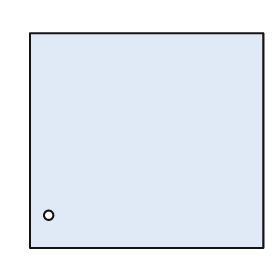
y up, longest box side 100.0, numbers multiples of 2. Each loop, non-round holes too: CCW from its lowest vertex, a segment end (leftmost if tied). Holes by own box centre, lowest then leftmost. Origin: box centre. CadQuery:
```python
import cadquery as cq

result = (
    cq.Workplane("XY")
    .moveTo(-50.0, -46.0)
    .lineTo(50.0, -46.0)
    .lineTo(50.0, 46.0)
    .lineTo(-50.0, 46.0)
    .close()
    .moveTo(-42.0, -32.0)
    .circle(2.0)
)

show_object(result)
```